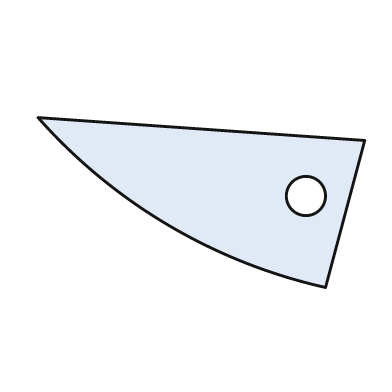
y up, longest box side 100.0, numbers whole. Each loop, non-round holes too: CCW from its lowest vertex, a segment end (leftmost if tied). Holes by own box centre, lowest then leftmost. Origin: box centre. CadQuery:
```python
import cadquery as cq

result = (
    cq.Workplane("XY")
    .moveTo(38.0, -26.0)
    .lineTo(50.0, 19.0)
    .lineTo(-50.0, 26.0)
    .threePointArc((-10.0, -7.0), (38.0, -26.0))
    .close()
    .moveTo(32.0, 2.0)
    .circle(6.0)
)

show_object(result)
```